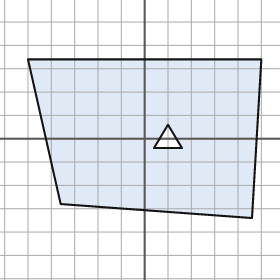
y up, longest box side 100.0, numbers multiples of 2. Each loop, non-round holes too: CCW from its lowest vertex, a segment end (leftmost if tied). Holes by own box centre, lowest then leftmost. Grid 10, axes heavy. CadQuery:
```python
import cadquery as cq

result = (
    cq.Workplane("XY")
    .moveTo(46.0, -34.0)
    .lineTo(50.0, 34.0)
    .lineTo(-50.0, 34.0)
    .lineTo(-36.0, -28.0)
    .close()
    .moveTo(4.0, -4.0)
    .lineTo(16.0, -4.0)
    .lineTo(10.0, 6.0)
    .close()
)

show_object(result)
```